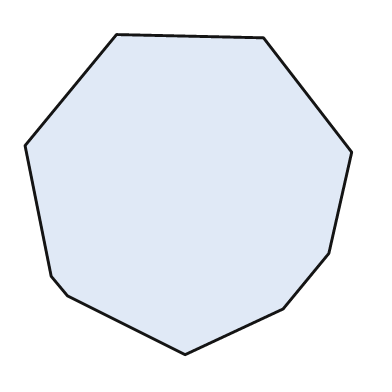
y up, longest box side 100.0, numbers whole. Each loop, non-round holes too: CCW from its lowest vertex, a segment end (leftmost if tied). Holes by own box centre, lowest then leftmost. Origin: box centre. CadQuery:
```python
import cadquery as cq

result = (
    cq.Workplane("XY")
    .moveTo(-1.0, -49.0)
    .lineTo(29.0, -35.0)
    .lineTo(43.0, -18.0)
    .lineTo(50.0, 13.0)
    .lineTo(23.0, 48.0)
    .lineTo(-22.0, 49.0)
    .lineTo(-50.0, 15.0)
    .lineTo(-42.0, -25.0)
    .lineTo(-37.0, -31.0)
    .close()
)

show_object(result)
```